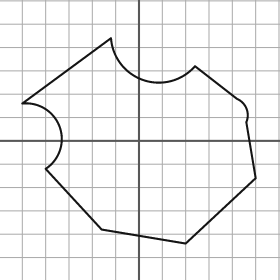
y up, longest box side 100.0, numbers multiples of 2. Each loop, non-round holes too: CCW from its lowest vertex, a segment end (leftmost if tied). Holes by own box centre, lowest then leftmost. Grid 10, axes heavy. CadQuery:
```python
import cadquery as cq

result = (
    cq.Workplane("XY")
    .moveTo(20.0, -44.0)
    .lineTo(50.0, -16.0)
    .lineTo(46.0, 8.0)
    .threePointArc((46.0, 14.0), (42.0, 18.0))
    .lineTo(24.0, 32.0)
    .threePointArc((2.0, 26.0), (-12.0, 44.0))
    .lineTo(-50.0, 16.0)
    .threePointArc((-34.0, 6.0), (-40.0, -12.0))
    .lineTo(-16.0, -38.0)
    .close()
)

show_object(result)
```